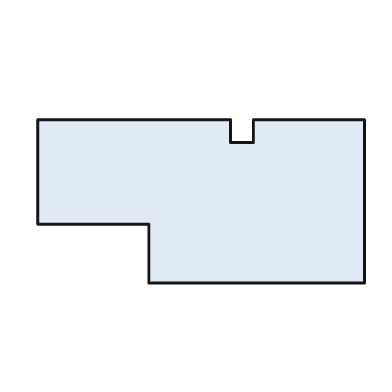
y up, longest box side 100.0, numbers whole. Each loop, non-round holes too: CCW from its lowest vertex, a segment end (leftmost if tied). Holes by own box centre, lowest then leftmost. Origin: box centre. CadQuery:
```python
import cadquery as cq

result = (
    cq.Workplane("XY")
    .moveTo(-16.0, -25.0)
    .lineTo(50.0, -25.0)
    .lineTo(50.0, 25.0)
    .lineTo(16.0, 25.0)
    .lineTo(16.0, 18.0)
    .lineTo(9.0, 18.0)
    .lineTo(9.0, 25.0)
    .lineTo(-50.0, 25.0)
    .lineTo(-50.0, -7.0)
    .lineTo(-16.0, -7.0)
    .close()
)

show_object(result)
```